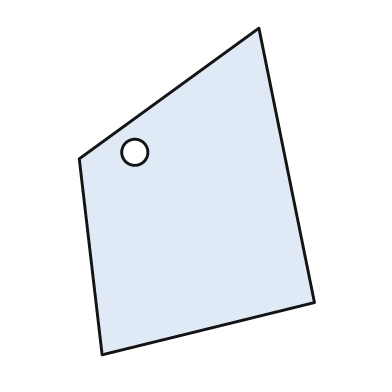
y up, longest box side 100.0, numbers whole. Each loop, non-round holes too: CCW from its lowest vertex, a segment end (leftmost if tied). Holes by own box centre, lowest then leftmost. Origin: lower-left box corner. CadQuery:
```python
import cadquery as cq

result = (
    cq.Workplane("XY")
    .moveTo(7.0, 0.0)
    .lineTo(72.0, 16.0)
    .lineTo(55.0, 100.0)
    .lineTo(0.0, 60.0)
    .close()
    .moveTo(17.0, 62.0)
    .circle(4.0)
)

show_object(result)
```